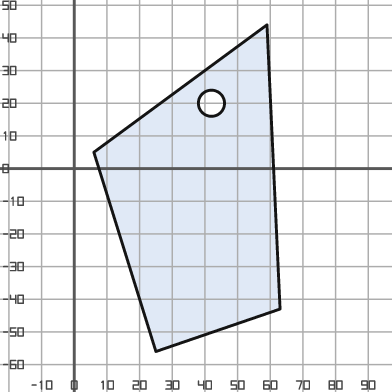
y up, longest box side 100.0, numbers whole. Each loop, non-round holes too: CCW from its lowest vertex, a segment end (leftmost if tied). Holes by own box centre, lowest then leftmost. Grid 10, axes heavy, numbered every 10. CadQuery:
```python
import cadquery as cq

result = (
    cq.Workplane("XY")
    .moveTo(25.0, -56.0)
    .lineTo(63.0, -43.0)
    .lineTo(59.0, 44.0)
    .lineTo(6.0, 5.0)
    .close()
    .moveTo(42.0, 20.0)
    .circle(4.0)
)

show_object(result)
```